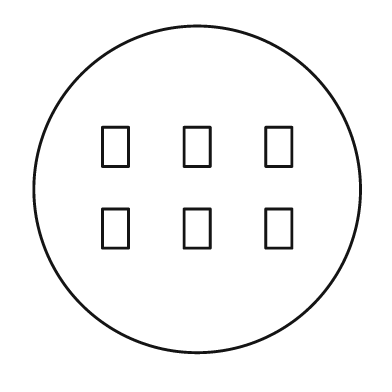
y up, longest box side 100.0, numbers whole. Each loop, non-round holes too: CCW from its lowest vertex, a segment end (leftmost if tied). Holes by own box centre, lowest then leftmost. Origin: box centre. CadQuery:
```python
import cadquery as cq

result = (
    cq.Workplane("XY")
    .moveTo(0.0, 0.0)
    .circle(50.0)
    .moveTo(-29.0, -18.0)
    .lineTo(-21.0, -18.0)
    .lineTo(-21.0, -6.0)
    .lineTo(-29.0, -6.0)
    .close()
    .moveTo(-4.0, -18.0)
    .lineTo(4.0, -18.0)
    .lineTo(4.0, -6.0)
    .lineTo(-4.0, -6.0)
    .close()
    .moveTo(21.0, -18.0)
    .lineTo(29.0, -18.0)
    .lineTo(29.0, -6.0)
    .lineTo(21.0, -6.0)
    .close()
    .moveTo(-29.0, 7.0)
    .lineTo(-21.0, 7.0)
    .lineTo(-21.0, 19.0)
    .lineTo(-29.0, 19.0)
    .close()
    .moveTo(-4.0, 7.0)
    .lineTo(4.0, 7.0)
    .lineTo(4.0, 19.0)
    .lineTo(-4.0, 19.0)
    .close()
    .moveTo(21.0, 7.0)
    .lineTo(29.0, 7.0)
    .lineTo(29.0, 19.0)
    .lineTo(21.0, 19.0)
    .close()
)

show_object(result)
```